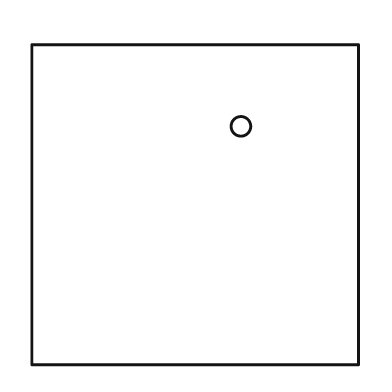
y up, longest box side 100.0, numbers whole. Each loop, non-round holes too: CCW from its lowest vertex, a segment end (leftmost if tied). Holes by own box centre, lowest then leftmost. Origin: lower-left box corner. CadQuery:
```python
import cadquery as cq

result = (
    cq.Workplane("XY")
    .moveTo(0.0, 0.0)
    .lineTo(100.0, 0.0)
    .lineTo(100.0, 98.0)
    .lineTo(0.0, 98.0)
    .close()
    .moveTo(64.0, 73.0)
    .circle(3.0)
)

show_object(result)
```